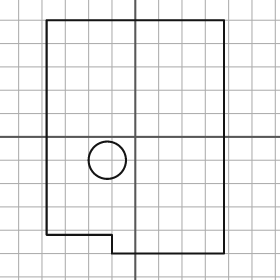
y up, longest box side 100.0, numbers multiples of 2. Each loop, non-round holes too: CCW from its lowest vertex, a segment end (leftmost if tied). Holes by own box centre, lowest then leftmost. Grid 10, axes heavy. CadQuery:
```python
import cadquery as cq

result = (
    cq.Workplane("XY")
    .moveTo(-10.0, -50.0)
    .lineTo(38.0, -50.0)
    .lineTo(38.0, 50.0)
    .lineTo(-38.0, 50.0)
    .lineTo(-38.0, -42.0)
    .lineTo(-10.0, -42.0)
    .close()
    .moveTo(-12.0, -10.0)
    .circle(8.0)
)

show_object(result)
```